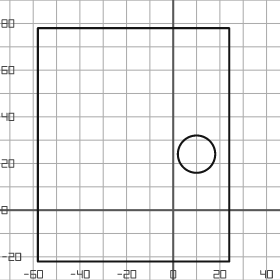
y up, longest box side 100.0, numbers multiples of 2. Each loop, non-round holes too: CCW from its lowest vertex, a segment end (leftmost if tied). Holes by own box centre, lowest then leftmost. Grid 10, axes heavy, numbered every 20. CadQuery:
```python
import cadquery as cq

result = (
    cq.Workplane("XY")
    .moveTo(-58.0, -22.0)
    .lineTo(24.0, -22.0)
    .lineTo(24.0, 78.0)
    .lineTo(-58.0, 78.0)
    .close()
    .moveTo(10.0, 24.0)
    .circle(8.0)
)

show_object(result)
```